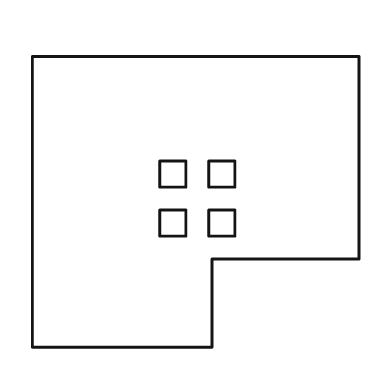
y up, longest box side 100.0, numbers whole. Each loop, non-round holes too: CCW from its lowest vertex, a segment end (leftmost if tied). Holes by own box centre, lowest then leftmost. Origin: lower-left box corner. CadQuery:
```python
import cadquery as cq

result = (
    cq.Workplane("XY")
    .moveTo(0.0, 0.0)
    .lineTo(55.0, 0.0)
    .lineTo(55.0, 27.0)
    .lineTo(100.0, 27.0)
    .lineTo(100.0, 89.0)
    .lineTo(0.0, 89.0)
    .close()
    .moveTo(39.0, 34.0)
    .lineTo(47.0, 34.0)
    .lineTo(47.0, 42.0)
    .lineTo(39.0, 42.0)
    .close()
    .moveTo(54.0, 34.0)
    .lineTo(62.0, 34.0)
    .lineTo(62.0, 42.0)
    .lineTo(54.0, 42.0)
    .close()
    .moveTo(39.0, 49.0)
    .lineTo(47.0, 49.0)
    .lineTo(47.0, 57.0)
    .lineTo(39.0, 57.0)
    .close()
    .moveTo(54.0, 49.0)
    .lineTo(62.0, 49.0)
    .lineTo(62.0, 57.0)
    .lineTo(54.0, 57.0)
    .close()
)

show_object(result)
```